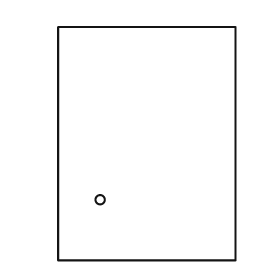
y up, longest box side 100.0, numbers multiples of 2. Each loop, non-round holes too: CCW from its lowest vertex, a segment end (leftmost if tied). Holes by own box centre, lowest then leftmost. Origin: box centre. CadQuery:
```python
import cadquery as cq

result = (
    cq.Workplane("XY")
    .moveTo(-38.0, -50.0)
    .lineTo(38.0, -50.0)
    .lineTo(38.0, 50.0)
    .lineTo(-38.0, 50.0)
    .close()
    .moveTo(-20.0, -24.0)
    .circle(2.0)
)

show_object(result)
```